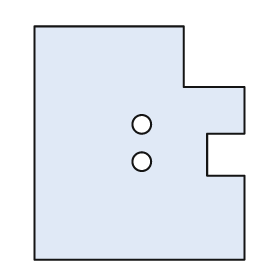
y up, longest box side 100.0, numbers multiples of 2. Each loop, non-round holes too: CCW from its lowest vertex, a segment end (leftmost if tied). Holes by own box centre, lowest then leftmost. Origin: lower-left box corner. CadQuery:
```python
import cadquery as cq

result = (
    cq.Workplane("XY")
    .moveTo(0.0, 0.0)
    .lineTo(90.0, 0.0)
    .lineTo(90.0, 36.0)
    .lineTo(74.0, 36.0)
    .lineTo(74.0, 54.0)
    .lineTo(90.0, 54.0)
    .lineTo(90.0, 74.0)
    .lineTo(64.0, 74.0)
    .lineTo(64.0, 100.0)
    .lineTo(0.0, 100.0)
    .close()
    .moveTo(46.0, 42.0)
    .circle(4.0)
    .moveTo(46.0, 58.0)
    .circle(4.0)
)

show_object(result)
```